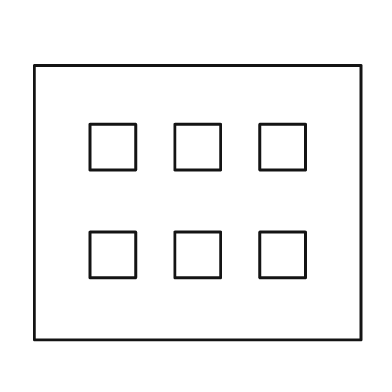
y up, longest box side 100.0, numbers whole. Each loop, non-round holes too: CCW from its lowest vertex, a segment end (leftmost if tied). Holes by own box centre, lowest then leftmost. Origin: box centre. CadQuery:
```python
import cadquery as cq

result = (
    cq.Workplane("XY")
    .moveTo(-50.0, -42.0)
    .lineTo(50.0, -42.0)
    .lineTo(50.0, 42.0)
    .lineTo(-50.0, 42.0)
    .close()
    .moveTo(-33.0, -23.0)
    .lineTo(-19.0, -23.0)
    .lineTo(-19.0, -9.0)
    .lineTo(-33.0, -9.0)
    .close()
    .moveTo(-7.0, -23.0)
    .lineTo(7.0, -23.0)
    .lineTo(7.0, -9.0)
    .lineTo(-7.0, -9.0)
    .close()
    .moveTo(19.0, -23.0)
    .lineTo(33.0, -23.0)
    .lineTo(33.0, -9.0)
    .lineTo(19.0, -9.0)
    .close()
    .moveTo(-33.0, 10.0)
    .lineTo(-19.0, 10.0)
    .lineTo(-19.0, 24.0)
    .lineTo(-33.0, 24.0)
    .close()
    .moveTo(-7.0, 10.0)
    .lineTo(7.0, 10.0)
    .lineTo(7.0, 24.0)
    .lineTo(-7.0, 24.0)
    .close()
    .moveTo(19.0, 10.0)
    .lineTo(33.0, 10.0)
    .lineTo(33.0, 24.0)
    .lineTo(19.0, 24.0)
    .close()
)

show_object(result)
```